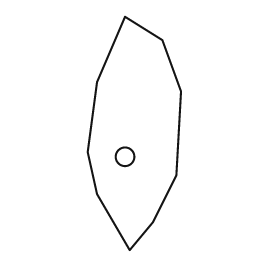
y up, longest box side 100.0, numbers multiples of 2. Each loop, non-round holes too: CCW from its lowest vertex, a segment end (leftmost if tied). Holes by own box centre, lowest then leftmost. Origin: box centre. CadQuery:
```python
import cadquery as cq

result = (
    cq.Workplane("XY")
    .moveTo(-2.0, -50.0)
    .lineTo(8.0, -38.0)
    .lineTo(18.0, -18.0)
    .lineTo(20.0, 18.0)
    .lineTo(12.0, 40.0)
    .lineTo(-4.0, 50.0)
    .lineTo(-16.0, 22.0)
    .lineTo(-20.0, -8.0)
    .lineTo(-16.0, -26.0)
    .close()
    .moveTo(-4.0, -10.0)
    .circle(4.0)
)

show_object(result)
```